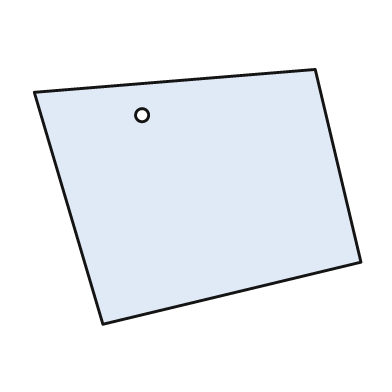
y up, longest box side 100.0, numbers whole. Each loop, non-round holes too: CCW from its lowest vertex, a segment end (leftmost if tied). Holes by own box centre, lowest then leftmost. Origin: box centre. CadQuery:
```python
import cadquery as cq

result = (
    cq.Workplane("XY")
    .moveTo(-29.0, -39.0)
    .lineTo(50.0, -20.0)
    .lineTo(36.0, 39.0)
    .lineTo(-50.0, 32.0)
    .close()
    .moveTo(-17.0, 25.0)
    .circle(2.0)
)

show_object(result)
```